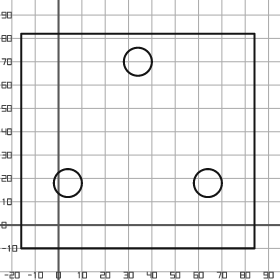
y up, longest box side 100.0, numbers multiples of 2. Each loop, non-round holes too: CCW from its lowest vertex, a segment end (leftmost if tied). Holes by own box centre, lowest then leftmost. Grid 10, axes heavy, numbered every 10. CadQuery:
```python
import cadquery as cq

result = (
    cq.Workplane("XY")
    .moveTo(-16.0, -10.0)
    .lineTo(84.0, -10.0)
    .lineTo(84.0, 82.0)
    .lineTo(-16.0, 82.0)
    .close()
    .moveTo(4.0, 18.0)
    .circle(6.0)
    .moveTo(64.0, 18.0)
    .circle(6.0)
    .moveTo(34.0, 70.0)
    .circle(6.0)
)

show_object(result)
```